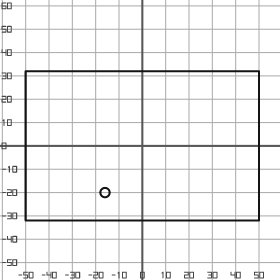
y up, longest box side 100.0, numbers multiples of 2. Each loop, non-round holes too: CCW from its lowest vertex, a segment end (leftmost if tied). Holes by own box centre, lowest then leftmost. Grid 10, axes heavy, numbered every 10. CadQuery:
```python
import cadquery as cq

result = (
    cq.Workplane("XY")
    .moveTo(-50.0, -32.0)
    .lineTo(50.0, -32.0)
    .lineTo(50.0, 32.0)
    .lineTo(-50.0, 32.0)
    .close()
    .moveTo(-16.0, -20.0)
    .circle(2.0)
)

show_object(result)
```